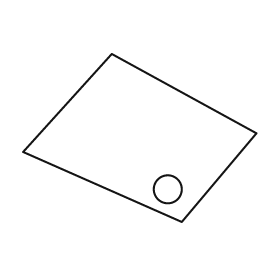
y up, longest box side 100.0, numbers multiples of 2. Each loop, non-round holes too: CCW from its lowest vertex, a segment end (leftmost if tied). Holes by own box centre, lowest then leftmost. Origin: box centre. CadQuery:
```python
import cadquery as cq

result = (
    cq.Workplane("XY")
    .moveTo(18.0, -36.0)
    .lineTo(50.0, 2.0)
    .lineTo(-12.0, 36.0)
    .lineTo(-50.0, -6.0)
    .close()
    .moveTo(12.0, -22.0)
    .circle(6.0)
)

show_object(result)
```